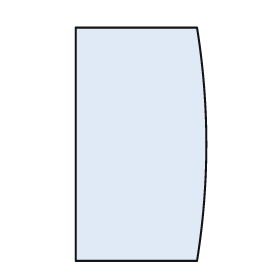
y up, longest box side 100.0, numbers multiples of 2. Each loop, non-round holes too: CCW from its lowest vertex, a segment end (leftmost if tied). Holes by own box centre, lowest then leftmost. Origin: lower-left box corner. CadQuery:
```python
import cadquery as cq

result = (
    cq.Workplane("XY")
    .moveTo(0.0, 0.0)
    .lineTo(52.0, 0.0)
    .threePointArc((56.0, 50.0), (52.0, 100.0))
    .lineTo(0.0, 100.0)
    .close()
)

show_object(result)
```